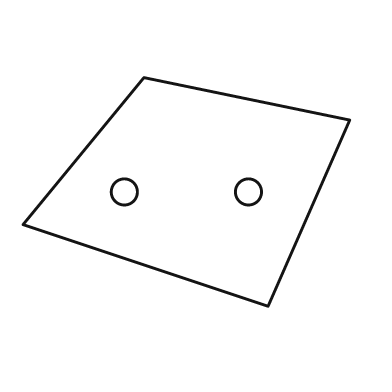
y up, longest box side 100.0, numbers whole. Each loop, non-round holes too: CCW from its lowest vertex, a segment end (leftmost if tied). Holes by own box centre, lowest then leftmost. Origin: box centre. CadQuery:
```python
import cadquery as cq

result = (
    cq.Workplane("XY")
    .moveTo(25.0, -35.0)
    .lineTo(50.0, 22.0)
    .lineTo(-13.0, 35.0)
    .lineTo(-50.0, -10.0)
    .close()
    .moveTo(-19.0, 0.0)
    .circle(4.0)
    .moveTo(19.0, 0.0)
    .circle(4.0)
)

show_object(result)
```